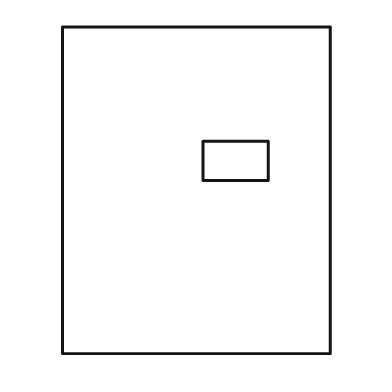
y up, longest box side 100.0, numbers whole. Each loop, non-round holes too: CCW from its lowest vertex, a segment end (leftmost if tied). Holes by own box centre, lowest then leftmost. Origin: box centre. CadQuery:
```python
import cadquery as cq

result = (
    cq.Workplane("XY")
    .moveTo(-41.0, -50.0)
    .lineTo(41.0, -50.0)
    .lineTo(41.0, 50.0)
    .lineTo(-41.0, 50.0)
    .close()
    .moveTo(2.0, 3.0)
    .lineTo(22.0, 3.0)
    .lineTo(22.0, 15.0)
    .lineTo(2.0, 15.0)
    .close()
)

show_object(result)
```